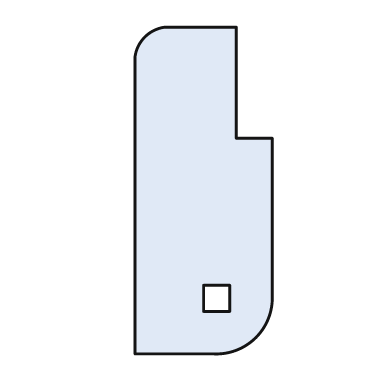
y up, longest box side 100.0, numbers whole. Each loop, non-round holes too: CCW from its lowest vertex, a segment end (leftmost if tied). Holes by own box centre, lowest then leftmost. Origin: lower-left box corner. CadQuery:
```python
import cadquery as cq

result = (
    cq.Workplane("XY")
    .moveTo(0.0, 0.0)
    .lineTo(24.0, 0.0)
    .threePointArc((37.0, 5.0), (42.0, 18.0))
    .lineTo(42.0, 66.0)
    .lineTo(31.0, 66.0)
    .lineTo(31.0, 100.0)
    .lineTo(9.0, 100.0)
    .threePointArc((3.0, 97.0), (0.0, 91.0))
    .close()
    .moveTo(21.0, 13.0)
    .lineTo(29.0, 13.0)
    .lineTo(29.0, 21.0)
    .lineTo(21.0, 21.0)
    .close()
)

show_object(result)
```